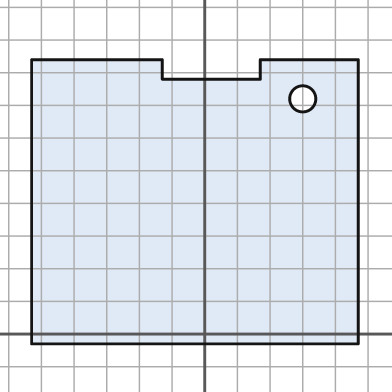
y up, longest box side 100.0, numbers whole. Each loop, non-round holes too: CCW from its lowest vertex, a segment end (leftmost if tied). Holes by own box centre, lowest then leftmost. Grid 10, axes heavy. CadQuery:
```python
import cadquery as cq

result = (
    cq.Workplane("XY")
    .moveTo(-53.0, -3.0)
    .lineTo(47.0, -3.0)
    .lineTo(47.0, 84.0)
    .lineTo(17.0, 84.0)
    .lineTo(17.0, 78.0)
    .lineTo(-13.0, 78.0)
    .lineTo(-13.0, 84.0)
    .lineTo(-53.0, 84.0)
    .close()
    .moveTo(30.0, 72.0)
    .circle(4.0)
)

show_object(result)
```